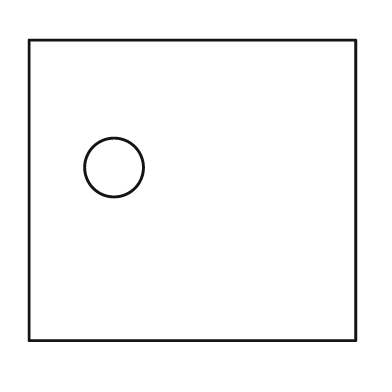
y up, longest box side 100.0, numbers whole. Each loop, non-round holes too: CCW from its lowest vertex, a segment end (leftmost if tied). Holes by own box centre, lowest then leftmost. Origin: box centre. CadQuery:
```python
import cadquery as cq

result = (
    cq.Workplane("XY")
    .moveTo(-50.0, -46.0)
    .lineTo(50.0, -46.0)
    .lineTo(50.0, 46.0)
    .lineTo(-50.0, 46.0)
    .close()
    .moveTo(-24.0, 7.0)
    .circle(9.0)
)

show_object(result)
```